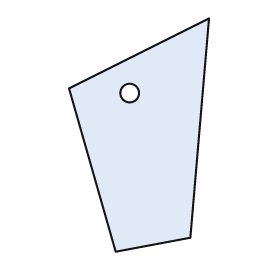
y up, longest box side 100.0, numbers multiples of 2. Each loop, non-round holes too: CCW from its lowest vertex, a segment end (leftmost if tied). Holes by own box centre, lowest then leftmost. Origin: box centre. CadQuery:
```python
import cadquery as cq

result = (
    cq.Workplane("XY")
    .moveTo(-10.0, -50.0)
    .lineTo(22.0, -44.0)
    .lineTo(30.0, 50.0)
    .lineTo(-30.0, 20.0)
    .close()
    .moveTo(-4.0, 18.0)
    .circle(4.0)
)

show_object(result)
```